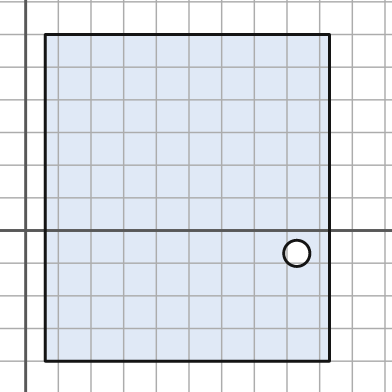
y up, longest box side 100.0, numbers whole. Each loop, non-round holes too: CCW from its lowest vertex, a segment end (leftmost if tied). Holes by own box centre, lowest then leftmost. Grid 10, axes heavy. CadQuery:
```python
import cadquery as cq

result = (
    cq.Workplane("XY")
    .moveTo(6.0, -40.0)
    .lineTo(93.0, -40.0)
    .lineTo(93.0, 60.0)
    .lineTo(6.0, 60.0)
    .close()
    .moveTo(83.0, -7.0)
    .circle(4.0)
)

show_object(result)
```